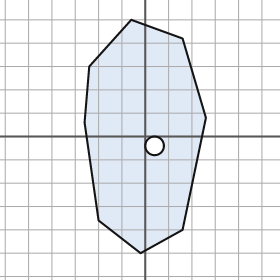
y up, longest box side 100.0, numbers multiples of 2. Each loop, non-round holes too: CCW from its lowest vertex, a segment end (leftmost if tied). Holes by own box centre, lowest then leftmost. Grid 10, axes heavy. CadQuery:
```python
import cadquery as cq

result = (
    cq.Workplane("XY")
    .moveTo(-2.0, -50.0)
    .lineTo(16.0, -40.0)
    .lineTo(26.0, 8.0)
    .lineTo(16.0, 42.0)
    .lineTo(-6.0, 50.0)
    .lineTo(-24.0, 30.0)
    .lineTo(-26.0, 6.0)
    .lineTo(-20.0, -36.0)
    .close()
    .moveTo(4.0, -4.0)
    .circle(4.0)
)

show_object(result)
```